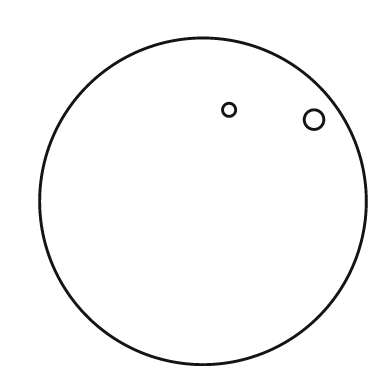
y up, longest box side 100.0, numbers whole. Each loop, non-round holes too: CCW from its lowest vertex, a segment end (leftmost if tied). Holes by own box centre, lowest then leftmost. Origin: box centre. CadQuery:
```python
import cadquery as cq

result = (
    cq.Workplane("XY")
    .moveTo(0.0, 0.0)
    .circle(50.0)
    .moveTo(34.0, 25.0)
    .circle(3.0)
    .moveTo(8.0, 28.0)
    .circle(2.0)
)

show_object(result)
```